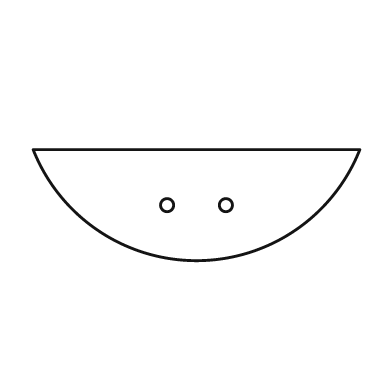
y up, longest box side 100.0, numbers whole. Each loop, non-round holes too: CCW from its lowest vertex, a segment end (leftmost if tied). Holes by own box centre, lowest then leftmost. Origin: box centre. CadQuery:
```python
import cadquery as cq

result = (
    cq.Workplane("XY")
    .moveTo(-50.0, 17.0)
    .threePointArc((0.0, -17.0), (50.0, 17.0))
    .close()
    .moveTo(-9.0, 0.0)
    .circle(2.0)
    .moveTo(9.0, 0.0)
    .circle(2.0)
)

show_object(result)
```